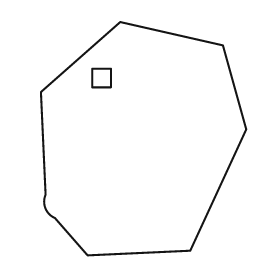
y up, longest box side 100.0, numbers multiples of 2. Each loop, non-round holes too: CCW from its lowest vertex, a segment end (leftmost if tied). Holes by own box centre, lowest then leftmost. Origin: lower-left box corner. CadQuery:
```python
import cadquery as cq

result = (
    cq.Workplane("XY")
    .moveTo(20.0, 0.0)
    .lineTo(64.0, 2.0)
    .lineTo(88.0, 54.0)
    .lineTo(78.0, 90.0)
    .lineTo(34.0, 100.0)
    .lineTo(0.0, 70.0)
    .lineTo(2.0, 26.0)
    .threePointArc((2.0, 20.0), (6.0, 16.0))
    .close()
    .moveTo(22.0, 72.0)
    .lineTo(30.0, 72.0)
    .lineTo(30.0, 80.0)
    .lineTo(22.0, 80.0)
    .close()
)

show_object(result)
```